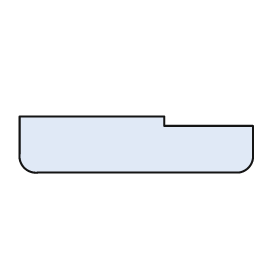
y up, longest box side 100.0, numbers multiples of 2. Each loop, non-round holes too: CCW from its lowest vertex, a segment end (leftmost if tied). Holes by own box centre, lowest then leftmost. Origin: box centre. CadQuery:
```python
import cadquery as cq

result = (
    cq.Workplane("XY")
    .moveTo(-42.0, -12.0)
    .lineTo(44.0, -12.0)
    .threePointArc((48.0, -10.0), (50.0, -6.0))
    .lineTo(50.0, 8.0)
    .lineTo(12.0, 8.0)
    .lineTo(12.0, 12.0)
    .lineTo(-50.0, 12.0)
    .lineTo(-50.0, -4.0)
    .threePointArc((-48.0, -10.0), (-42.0, -12.0))
    .close()
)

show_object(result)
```